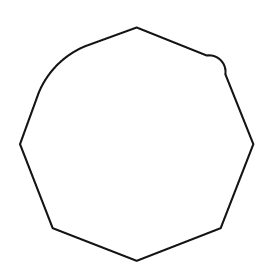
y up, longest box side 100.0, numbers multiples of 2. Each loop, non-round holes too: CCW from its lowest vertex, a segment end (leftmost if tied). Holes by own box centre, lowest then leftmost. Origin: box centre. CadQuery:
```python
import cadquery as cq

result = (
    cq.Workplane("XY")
    .moveTo(0.0, -50.0)
    .lineTo(36.0, -36.0)
    .lineTo(50.0, 0.0)
    .lineTo(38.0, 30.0)
    .threePointArc((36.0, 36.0), (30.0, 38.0))
    .lineTo(0.0, 50.0)
    .lineTo(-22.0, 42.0)
    .threePointArc((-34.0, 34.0), (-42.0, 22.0))
    .lineTo(-50.0, 0.0)
    .lineTo(-36.0, -36.0)
    .close()
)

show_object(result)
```